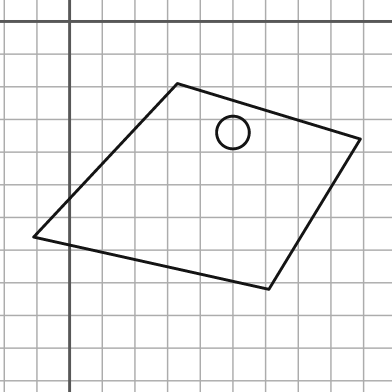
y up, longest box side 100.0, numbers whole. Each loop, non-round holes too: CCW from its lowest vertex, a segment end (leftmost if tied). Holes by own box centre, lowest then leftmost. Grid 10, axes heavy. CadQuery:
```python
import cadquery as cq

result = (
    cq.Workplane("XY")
    .moveTo(61.0, -82.0)
    .lineTo(89.0, -36.0)
    .lineTo(33.0, -19.0)
    .lineTo(-11.0, -66.0)
    .close()
    .moveTo(50.0, -34.0)
    .circle(5.0)
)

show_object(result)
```